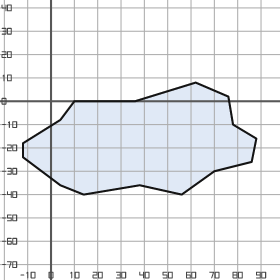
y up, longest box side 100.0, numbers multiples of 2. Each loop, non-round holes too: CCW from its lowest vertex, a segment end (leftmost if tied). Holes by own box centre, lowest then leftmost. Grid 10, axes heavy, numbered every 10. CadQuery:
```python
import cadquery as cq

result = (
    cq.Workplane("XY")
    .moveTo(14.0, -40.0)
    .lineTo(38.0, -36.0)
    .lineTo(56.0, -40.0)
    .lineTo(70.0, -30.0)
    .lineTo(86.0, -26.0)
    .lineTo(88.0, -16.0)
    .lineTo(78.0, -10.0)
    .lineTo(76.0, 2.0)
    .lineTo(62.0, 8.0)
    .lineTo(36.0, 0.0)
    .lineTo(10.0, 0.0)
    .lineTo(4.0, -8.0)
    .lineTo(-12.0, -18.0)
    .lineTo(-12.0, -24.0)
    .lineTo(4.0, -36.0)
    .close()
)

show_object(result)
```